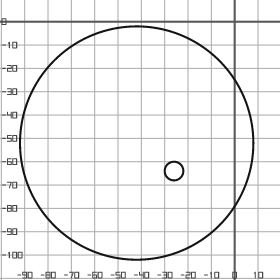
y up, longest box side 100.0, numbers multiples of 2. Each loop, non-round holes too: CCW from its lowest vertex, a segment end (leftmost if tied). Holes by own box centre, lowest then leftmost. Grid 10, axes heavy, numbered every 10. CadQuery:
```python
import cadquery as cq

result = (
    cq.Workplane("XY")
    .moveTo(-42.0, -52.0)
    .circle(50.0)
    .moveTo(-26.0, -64.0)
    .circle(4.0)
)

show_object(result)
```